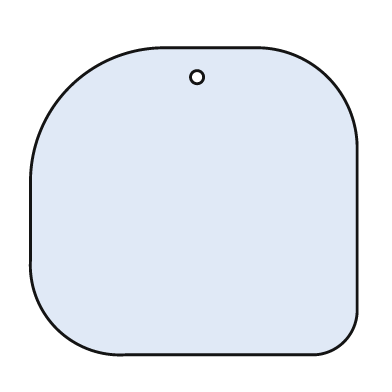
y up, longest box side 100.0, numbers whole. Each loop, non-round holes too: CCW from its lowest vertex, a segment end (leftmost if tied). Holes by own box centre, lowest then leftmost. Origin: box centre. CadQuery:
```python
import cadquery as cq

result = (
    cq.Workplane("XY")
    .moveTo(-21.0, -47.0)
    .lineTo(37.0, -47.0)
    .threePointArc((46.0, -43.0), (50.0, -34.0))
    .lineTo(50.0, 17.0)
    .threePointArc((41.0, 38.0), (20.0, 47.0))
    .lineTo(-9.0, 47.0)
    .threePointArc((-38.0, 35.0), (-50.0, 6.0))
    .lineTo(-50.0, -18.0)
    .threePointArc((-42.0, -39.0), (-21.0, -47.0))
    .close()
    .moveTo(1.0, 38.0)
    .circle(2.0)
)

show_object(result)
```